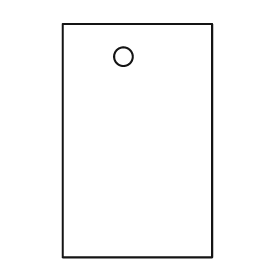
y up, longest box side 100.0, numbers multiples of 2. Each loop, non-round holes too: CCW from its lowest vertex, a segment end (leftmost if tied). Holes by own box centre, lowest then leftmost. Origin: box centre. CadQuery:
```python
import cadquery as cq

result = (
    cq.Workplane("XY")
    .moveTo(-32.0, -50.0)
    .lineTo(32.0, -50.0)
    .lineTo(32.0, 50.0)
    .lineTo(-32.0, 50.0)
    .close()
    .moveTo(-6.0, 36.0)
    .circle(4.0)
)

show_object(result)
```